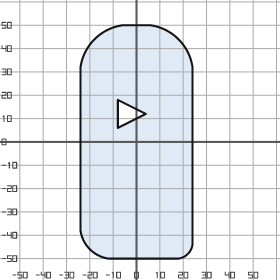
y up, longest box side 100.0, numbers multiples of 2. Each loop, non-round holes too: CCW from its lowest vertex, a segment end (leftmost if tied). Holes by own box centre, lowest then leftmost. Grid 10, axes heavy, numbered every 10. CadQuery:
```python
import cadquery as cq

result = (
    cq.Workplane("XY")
    .moveTo(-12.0, -50.0)
    .lineTo(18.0, -50.0)
    .threePointArc((22.0, -48.0), (24.0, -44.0))
    .lineTo(24.0, 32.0)
    .threePointArc((18.0, 44.0), (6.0, 50.0))
    .lineTo(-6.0, 50.0)
    .threePointArc((-18.0, 44.0), (-24.0, 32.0))
    .lineTo(-24.0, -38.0)
    .threePointArc((-20.0, -46.0), (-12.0, -50.0))
    .close()
    .moveTo(-8.0, 6.0)
    .lineTo(4.0, 12.0)
    .lineTo(-8.0, 18.0)
    .close()
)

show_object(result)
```